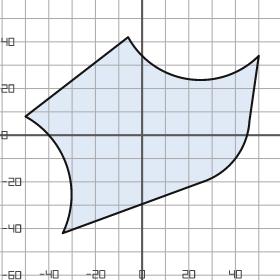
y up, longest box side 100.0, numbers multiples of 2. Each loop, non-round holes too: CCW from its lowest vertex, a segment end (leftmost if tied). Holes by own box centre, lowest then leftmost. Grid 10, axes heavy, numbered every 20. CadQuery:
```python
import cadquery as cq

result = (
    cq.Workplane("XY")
    .moveTo(-34.0, -42.0)
    .lineTo(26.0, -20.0)
    .threePointArc((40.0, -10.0), (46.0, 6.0))
    .lineTo(50.0, 34.0)
    .threePointArc((20.0, 24.0), (-6.0, 42.0))
    .lineTo(-50.0, 8.0)
    .threePointArc((-32.0, -14.0), (-34.0, -42.0))
    .close()
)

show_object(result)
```